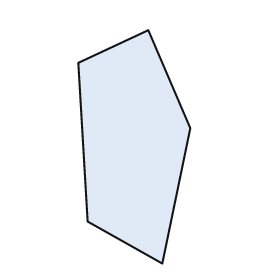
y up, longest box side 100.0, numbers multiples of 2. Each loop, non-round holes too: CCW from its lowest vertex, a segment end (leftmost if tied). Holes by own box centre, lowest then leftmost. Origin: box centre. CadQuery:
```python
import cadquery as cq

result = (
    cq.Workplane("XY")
    .moveTo(12.0, -50.0)
    .lineTo(24.0, 8.0)
    .lineTo(6.0, 50.0)
    .lineTo(-24.0, 36.0)
    .lineTo(-20.0, -32.0)
    .close()
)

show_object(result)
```